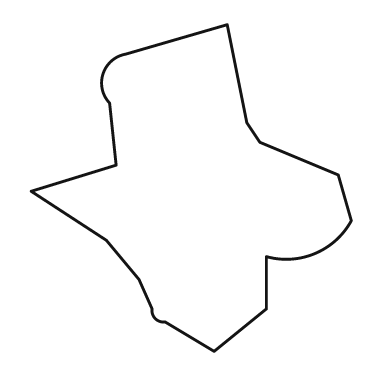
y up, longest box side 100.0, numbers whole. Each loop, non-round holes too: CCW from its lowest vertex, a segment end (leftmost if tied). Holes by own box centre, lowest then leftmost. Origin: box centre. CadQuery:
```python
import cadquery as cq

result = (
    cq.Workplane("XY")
    .moveTo(7.0, -50.0)
    .lineTo(23.0, -37.0)
    .lineTo(23.0, -21.0)
    .threePointArc((38.0, -20.0), (49.0, -10.0))
    .lineTo(45.0, 4.0)
    .lineTo(21.0, 14.0)
    .lineTo(17.0, 20.0)
    .lineTo(11.0, 50.0)
    .lineTo(-20.0, 41.0)
    .threePointArc((-27.0, 35.0), (-25.0, 26.0))
    .lineTo(-23.0, 7.0)
    .lineTo(-49.0, -1.0)
    .lineTo(-26.0, -16.0)
    .lineTo(-16.0, -28.0)
    .lineTo(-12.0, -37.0)
    .threePointArc((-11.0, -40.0), (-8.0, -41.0))
    .close()
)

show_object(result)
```